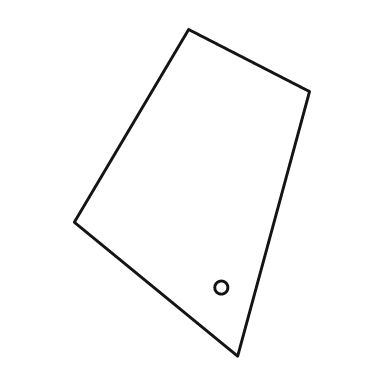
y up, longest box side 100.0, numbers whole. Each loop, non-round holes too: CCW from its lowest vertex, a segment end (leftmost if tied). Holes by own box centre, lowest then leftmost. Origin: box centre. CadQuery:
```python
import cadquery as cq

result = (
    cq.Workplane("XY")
    .moveTo(14.0, -50.0)
    .lineTo(36.0, 31.0)
    .lineTo(-1.0, 50.0)
    .lineTo(-36.0, -9.0)
    .close()
    .moveTo(9.0, -29.0)
    .circle(2.0)
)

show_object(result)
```